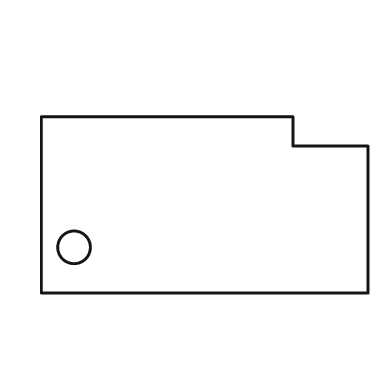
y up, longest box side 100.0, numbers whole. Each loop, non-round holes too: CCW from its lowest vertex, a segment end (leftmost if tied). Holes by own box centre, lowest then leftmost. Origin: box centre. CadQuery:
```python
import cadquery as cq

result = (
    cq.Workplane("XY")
    .moveTo(-50.0, -27.0)
    .lineTo(50.0, -27.0)
    .lineTo(50.0, 18.0)
    .lineTo(27.0, 18.0)
    .lineTo(27.0, 27.0)
    .lineTo(-50.0, 27.0)
    .close()
    .moveTo(-40.0, -13.0)
    .circle(5.0)
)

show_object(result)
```